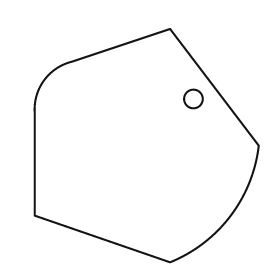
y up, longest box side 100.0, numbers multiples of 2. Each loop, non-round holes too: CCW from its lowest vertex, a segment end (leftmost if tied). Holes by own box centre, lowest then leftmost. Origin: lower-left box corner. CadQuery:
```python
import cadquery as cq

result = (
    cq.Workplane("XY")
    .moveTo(58.0, 0.0)
    .threePointArc((84.0, 20.0), (96.0, 50.0))
    .lineTo(58.0, 100.0)
    .lineTo(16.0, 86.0)
    .threePointArc((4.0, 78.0), (0.0, 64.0))
    .lineTo(0.0, 20.0)
    .close()
    .moveTo(68.0, 70.0)
    .circle(4.0)
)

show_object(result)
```